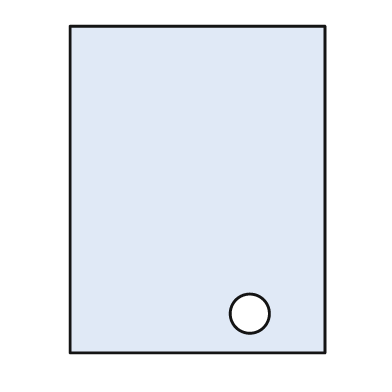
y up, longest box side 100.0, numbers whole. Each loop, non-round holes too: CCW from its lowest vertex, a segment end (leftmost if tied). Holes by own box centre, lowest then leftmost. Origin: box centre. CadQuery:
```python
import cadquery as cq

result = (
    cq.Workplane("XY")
    .moveTo(-39.0, -50.0)
    .lineTo(39.0, -50.0)
    .lineTo(39.0, 50.0)
    .lineTo(-39.0, 50.0)
    .close()
    .moveTo(16.0, -38.0)
    .circle(6.0)
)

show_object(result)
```